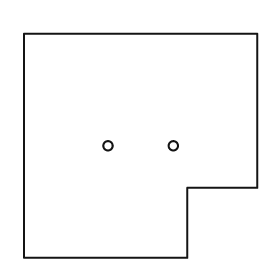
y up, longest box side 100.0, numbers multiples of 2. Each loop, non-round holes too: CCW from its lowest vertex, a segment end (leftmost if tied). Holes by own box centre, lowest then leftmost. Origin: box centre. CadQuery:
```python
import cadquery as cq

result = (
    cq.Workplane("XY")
    .moveTo(-50.0, -48.0)
    .lineTo(20.0, -48.0)
    .lineTo(20.0, -18.0)
    .lineTo(50.0, -18.0)
    .lineTo(50.0, 48.0)
    .lineTo(-50.0, 48.0)
    .close()
    .moveTo(-14.0, 0.0)
    .circle(2.0)
    .moveTo(14.0, 0.0)
    .circle(2.0)
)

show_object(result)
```